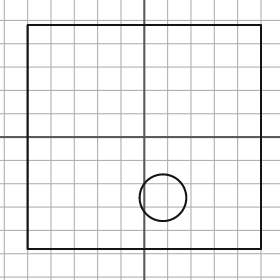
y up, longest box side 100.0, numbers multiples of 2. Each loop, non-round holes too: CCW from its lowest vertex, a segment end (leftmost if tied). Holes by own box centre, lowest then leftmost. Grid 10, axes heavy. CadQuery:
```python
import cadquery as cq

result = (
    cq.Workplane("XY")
    .moveTo(-50.0, -48.0)
    .lineTo(50.0, -48.0)
    .lineTo(50.0, 48.0)
    .lineTo(-50.0, 48.0)
    .close()
    .moveTo(8.0, -26.0)
    .circle(10.0)
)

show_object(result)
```